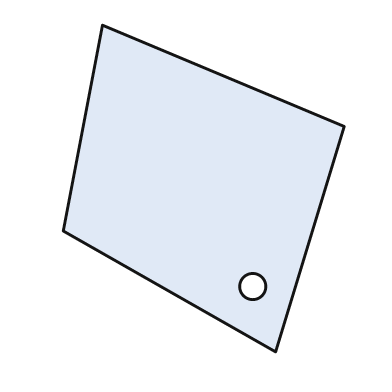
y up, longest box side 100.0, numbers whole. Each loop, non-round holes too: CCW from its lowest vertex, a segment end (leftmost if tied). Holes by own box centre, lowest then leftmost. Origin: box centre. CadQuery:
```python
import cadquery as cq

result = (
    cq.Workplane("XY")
    .moveTo(22.0, -50.0)
    .lineTo(43.0, 19.0)
    .lineTo(-31.0, 50.0)
    .lineTo(-43.0, -13.0)
    .close()
    .moveTo(15.0, -30.0)
    .circle(4.0)
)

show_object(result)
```